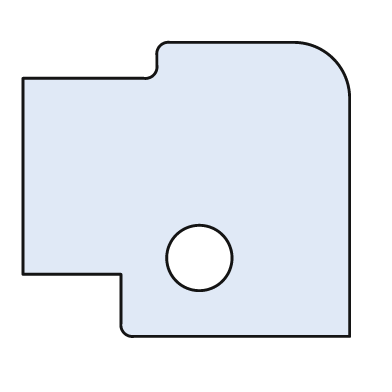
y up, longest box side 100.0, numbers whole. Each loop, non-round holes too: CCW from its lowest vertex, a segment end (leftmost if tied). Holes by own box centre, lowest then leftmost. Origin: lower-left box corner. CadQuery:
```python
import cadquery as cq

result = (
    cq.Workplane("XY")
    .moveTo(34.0, 0.0)
    .lineTo(100.0, 0.0)
    .lineTo(100.0, 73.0)
    .threePointArc((95.0, 85.0), (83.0, 90.0))
    .lineTo(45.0, 90.0)
    .threePointArc((42.0, 89.0), (41.0, 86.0))
    .lineTo(41.0, 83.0)
    .threePointArc((40.0, 80.0), (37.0, 79.0))
    .lineTo(0.0, 79.0)
    .lineTo(0.0, 19.0)
    .lineTo(30.0, 19.0)
    .lineTo(30.0, 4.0)
    .threePointArc((31.0, 1.0), (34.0, 0.0))
    .close()
    .moveTo(54.0, 24.0)
    .circle(10.0)
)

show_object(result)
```